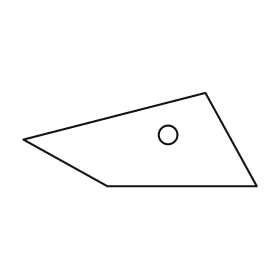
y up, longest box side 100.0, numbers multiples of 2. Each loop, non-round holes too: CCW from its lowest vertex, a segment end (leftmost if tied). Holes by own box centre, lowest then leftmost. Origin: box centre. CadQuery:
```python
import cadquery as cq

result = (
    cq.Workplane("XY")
    .moveTo(-14.0, -20.0)
    .lineTo(50.0, -20.0)
    .lineTo(28.0, 20.0)
    .lineTo(-50.0, 0.0)
    .close()
    .moveTo(12.0, 2.0)
    .circle(4.0)
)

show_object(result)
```